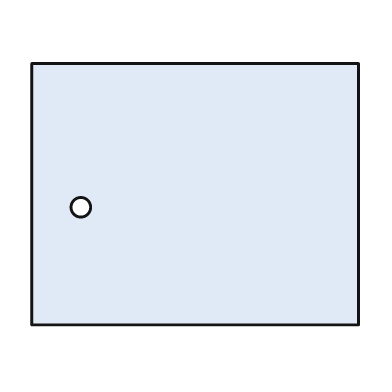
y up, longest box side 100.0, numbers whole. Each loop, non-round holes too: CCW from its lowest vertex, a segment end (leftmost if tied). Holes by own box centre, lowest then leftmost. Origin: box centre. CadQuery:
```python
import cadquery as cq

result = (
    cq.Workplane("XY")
    .moveTo(-50.0, -40.0)
    .lineTo(50.0, -40.0)
    .lineTo(50.0, 40.0)
    .lineTo(-50.0, 40.0)
    .close()
    .moveTo(-35.0, -4.0)
    .circle(3.0)
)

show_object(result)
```